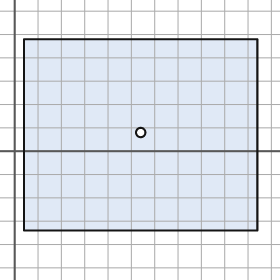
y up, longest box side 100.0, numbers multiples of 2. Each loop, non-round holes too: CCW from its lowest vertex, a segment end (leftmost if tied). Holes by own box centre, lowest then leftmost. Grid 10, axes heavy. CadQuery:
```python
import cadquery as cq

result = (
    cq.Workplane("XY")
    .moveTo(4.0, -34.0)
    .lineTo(104.0, -34.0)
    .lineTo(104.0, 48.0)
    .lineTo(4.0, 48.0)
    .close()
    .moveTo(54.0, 8.0)
    .circle(2.0)
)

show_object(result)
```